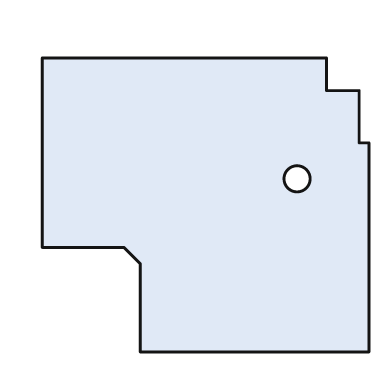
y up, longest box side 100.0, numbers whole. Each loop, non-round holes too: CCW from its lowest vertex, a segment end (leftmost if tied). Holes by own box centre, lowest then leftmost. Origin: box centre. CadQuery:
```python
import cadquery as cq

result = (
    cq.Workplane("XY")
    .moveTo(-20.0, -45.0)
    .lineTo(50.0, -45.0)
    .lineTo(50.0, 19.0)
    .lineTo(47.0, 19.0)
    .lineTo(47.0, 35.0)
    .lineTo(37.0, 35.0)
    .lineTo(37.0, 45.0)
    .lineTo(-50.0, 45.0)
    .lineTo(-50.0, -13.0)
    .lineTo(-25.0, -13.0)
    .lineTo(-20.0, -18.0)
    .close()
    .moveTo(28.0, 8.0)
    .circle(4.0)
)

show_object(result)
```